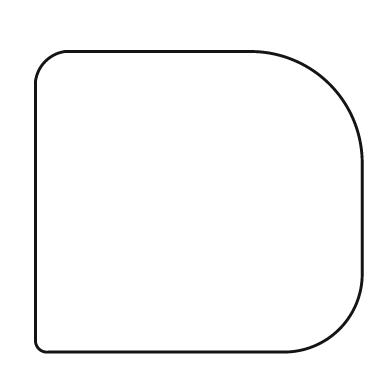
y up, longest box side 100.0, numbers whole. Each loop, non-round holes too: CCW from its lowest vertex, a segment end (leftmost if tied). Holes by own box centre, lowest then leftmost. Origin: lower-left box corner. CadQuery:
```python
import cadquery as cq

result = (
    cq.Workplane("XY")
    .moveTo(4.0, 0.0)
    .lineTo(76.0, 0.0)
    .threePointArc((93.0, 7.0), (100.0, 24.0))
    .lineTo(100.0, 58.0)
    .threePointArc((90.0, 82.0), (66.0, 92.0))
    .lineTo(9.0, 92.0)
    .threePointArc((3.0, 89.0), (0.0, 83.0))
    .lineTo(0.0, 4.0)
    .threePointArc((1.0, 1.0), (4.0, 0.0))
    .close()
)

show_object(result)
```